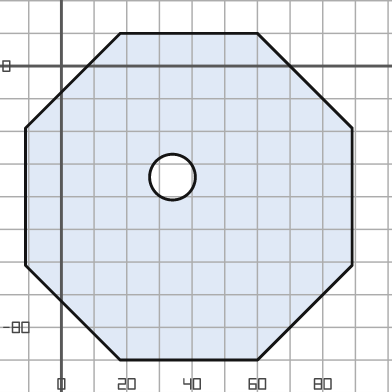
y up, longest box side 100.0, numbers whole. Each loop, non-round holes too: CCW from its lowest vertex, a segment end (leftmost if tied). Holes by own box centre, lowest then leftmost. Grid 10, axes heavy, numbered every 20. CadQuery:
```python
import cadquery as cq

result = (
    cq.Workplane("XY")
    .moveTo(18.0, -90.0)
    .lineTo(60.0, -90.0)
    .lineTo(89.0, -61.0)
    .lineTo(89.0, -19.0)
    .lineTo(60.0, 10.0)
    .lineTo(18.0, 10.0)
    .lineTo(-11.0, -19.0)
    .lineTo(-11.0, -61.0)
    .close()
    .moveTo(34.0, -34.0)
    .circle(7.0)
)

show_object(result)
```